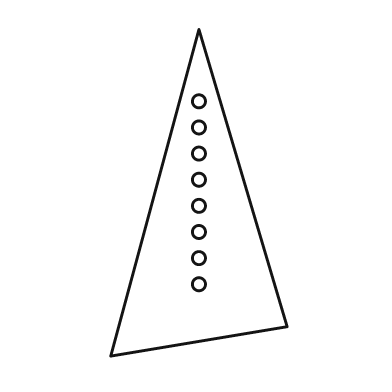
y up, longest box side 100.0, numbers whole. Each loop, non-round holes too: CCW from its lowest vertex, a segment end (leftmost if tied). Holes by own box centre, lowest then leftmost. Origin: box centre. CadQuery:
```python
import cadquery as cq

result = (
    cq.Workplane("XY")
    .moveTo(-27.0, -50.0)
    .lineTo(27.0, -41.0)
    .lineTo(0.0, 50.0)
    .close()
    .moveTo(0.0, -28.0)
    .circle(2.0)
    .moveTo(0.0, -20.0)
    .circle(2.0)
    .moveTo(0.0, -12.0)
    .circle(2.0)
    .moveTo(0.0, -4.0)
    .circle(2.0)
    .moveTo(0.0, 4.0)
    .circle(2.0)
    .moveTo(0.0, 12.0)
    .circle(2.0)
    .moveTo(0.0, 20.0)
    .circle(2.0)
    .moveTo(0.0, 28.0)
    .circle(2.0)
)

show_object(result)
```